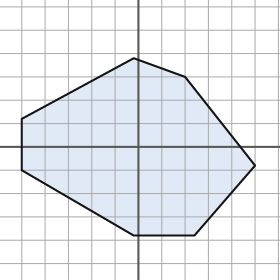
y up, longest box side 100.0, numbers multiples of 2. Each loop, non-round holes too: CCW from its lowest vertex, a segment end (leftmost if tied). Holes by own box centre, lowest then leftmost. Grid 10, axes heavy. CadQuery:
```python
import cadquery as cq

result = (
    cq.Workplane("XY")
    .moveTo(-2.0, -38.0)
    .lineTo(24.0, -38.0)
    .lineTo(50.0, -8.0)
    .lineTo(20.0, 30.0)
    .lineTo(-2.0, 38.0)
    .lineTo(-50.0, 12.0)
    .lineTo(-50.0, -10.0)
    .close()
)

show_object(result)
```